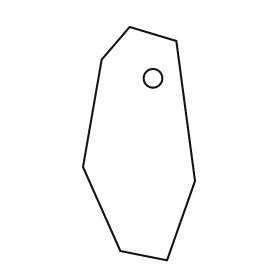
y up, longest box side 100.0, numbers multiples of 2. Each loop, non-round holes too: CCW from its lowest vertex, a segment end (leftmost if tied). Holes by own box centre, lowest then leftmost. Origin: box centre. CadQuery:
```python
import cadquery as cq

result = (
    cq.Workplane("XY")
    .moveTo(12.0, -50.0)
    .lineTo(24.0, -16.0)
    .lineTo(16.0, 44.0)
    .lineTo(-4.0, 50.0)
    .lineTo(-16.0, 36.0)
    .lineTo(-24.0, -10.0)
    .lineTo(-8.0, -46.0)
    .close()
    .moveTo(6.0, 28.0)
    .circle(4.0)
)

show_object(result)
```